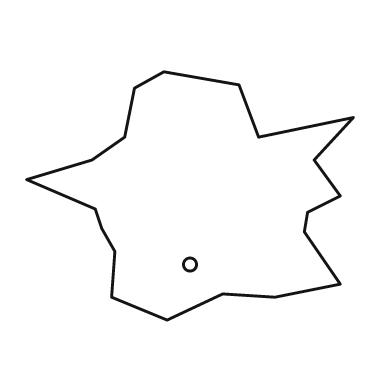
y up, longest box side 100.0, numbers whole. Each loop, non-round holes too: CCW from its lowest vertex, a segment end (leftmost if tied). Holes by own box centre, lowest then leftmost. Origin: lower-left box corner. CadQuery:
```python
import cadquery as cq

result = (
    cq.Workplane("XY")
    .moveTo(43.0, 0.0)
    .lineTo(60.0, 8.0)
    .lineTo(76.0, 7.0)
    .lineTo(96.0, 11.0)
    .lineTo(85.0, 27.0)
    .lineTo(86.0, 33.0)
    .lineTo(96.0, 38.0)
    .lineTo(88.0, 49.0)
    .lineTo(100.0, 62.0)
    .lineTo(71.0, 56.0)
    .lineTo(65.0, 72.0)
    .lineTo(42.0, 76.0)
    .lineTo(33.0, 71.0)
    .lineTo(30.0, 56.0)
    .lineTo(20.0, 49.0)
    .lineTo(0.0, 43.0)
    .lineTo(21.0, 34.0)
    .lineTo(23.0, 28.0)
    .lineTo(27.0, 21.0)
    .lineTo(26.0, 7.0)
    .close()
    .moveTo(50.0, 17.0)
    .circle(2.0)
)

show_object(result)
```